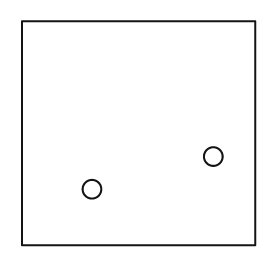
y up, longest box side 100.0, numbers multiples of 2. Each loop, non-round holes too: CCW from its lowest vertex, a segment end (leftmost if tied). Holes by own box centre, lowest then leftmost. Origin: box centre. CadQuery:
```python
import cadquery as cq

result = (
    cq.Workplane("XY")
    .moveTo(-50.0, -48.0)
    .lineTo(50.0, -48.0)
    .lineTo(50.0, 48.0)
    .lineTo(-50.0, 48.0)
    .close()
    .moveTo(-20.0, -24.0)
    .circle(4.0)
    .moveTo(32.0, -10.0)
    .circle(4.0)
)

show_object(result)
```